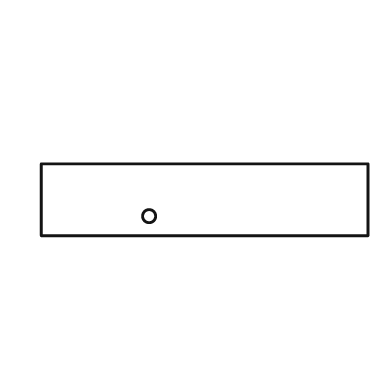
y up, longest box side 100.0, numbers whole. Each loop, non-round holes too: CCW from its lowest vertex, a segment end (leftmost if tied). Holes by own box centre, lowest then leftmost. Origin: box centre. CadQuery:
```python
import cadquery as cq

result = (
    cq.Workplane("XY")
    .moveTo(-50.0, -11.0)
    .lineTo(50.0, -11.0)
    .lineTo(50.0, 11.0)
    .lineTo(-50.0, 11.0)
    .close()
    .moveTo(-17.0, -5.0)
    .circle(2.0)
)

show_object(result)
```